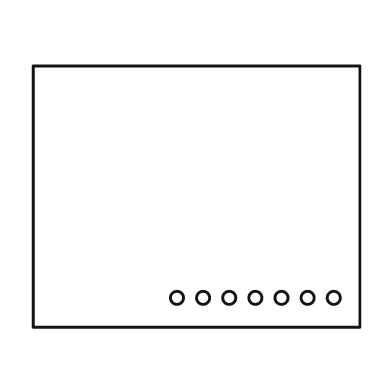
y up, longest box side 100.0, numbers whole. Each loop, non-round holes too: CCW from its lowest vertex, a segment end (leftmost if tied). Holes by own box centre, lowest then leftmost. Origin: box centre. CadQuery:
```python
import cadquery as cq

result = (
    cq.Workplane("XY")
    .moveTo(-50.0, -40.0)
    .lineTo(50.0, -40.0)
    .lineTo(50.0, 40.0)
    .lineTo(-50.0, 40.0)
    .close()
    .moveTo(-6.0, -31.0)
    .circle(2.0)
    .moveTo(2.0, -31.0)
    .circle(2.0)
    .moveTo(10.0, -31.0)
    .circle(2.0)
    .moveTo(18.0, -31.0)
    .circle(2.0)
    .moveTo(26.0, -31.0)
    .circle(2.0)
    .moveTo(34.0, -31.0)
    .circle(2.0)
    .moveTo(42.0, -31.0)
    .circle(2.0)
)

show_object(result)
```